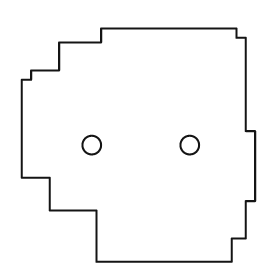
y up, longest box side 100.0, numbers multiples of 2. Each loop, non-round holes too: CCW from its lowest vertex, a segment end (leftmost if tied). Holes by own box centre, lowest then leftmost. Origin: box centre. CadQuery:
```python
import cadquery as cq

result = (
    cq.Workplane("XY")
    .moveTo(-18.0, -50.0)
    .lineTo(40.0, -50.0)
    .lineTo(40.0, -40.0)
    .lineTo(46.0, -40.0)
    .lineTo(46.0, -24.0)
    .lineTo(50.0, -24.0)
    .lineTo(50.0, 6.0)
    .lineTo(46.0, 6.0)
    .lineTo(46.0, 46.0)
    .lineTo(42.0, 46.0)
    .lineTo(42.0, 50.0)
    .lineTo(-16.0, 50.0)
    .lineTo(-16.0, 44.0)
    .lineTo(-34.0, 44.0)
    .lineTo(-34.0, 32.0)
    .lineTo(-46.0, 32.0)
    .lineTo(-46.0, 28.0)
    .lineTo(-50.0, 28.0)
    .lineTo(-50.0, -14.0)
    .lineTo(-38.0, -14.0)
    .lineTo(-38.0, -28.0)
    .lineTo(-18.0, -28.0)
    .close()
    .moveTo(-20.0, 0.0)
    .circle(4.0)
    .moveTo(22.0, 0.0)
    .circle(4.0)
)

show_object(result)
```